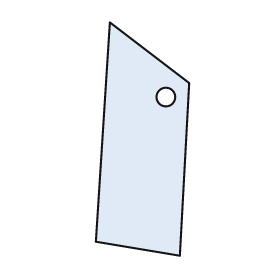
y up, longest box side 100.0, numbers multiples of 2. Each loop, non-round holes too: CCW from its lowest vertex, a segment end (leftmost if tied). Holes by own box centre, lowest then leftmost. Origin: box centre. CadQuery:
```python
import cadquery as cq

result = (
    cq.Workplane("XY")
    .moveTo(16.0, -50.0)
    .lineTo(20.0, 24.0)
    .lineTo(-14.0, 50.0)
    .lineTo(-20.0, -44.0)
    .close()
    .moveTo(10.0, 18.0)
    .circle(4.0)
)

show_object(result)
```